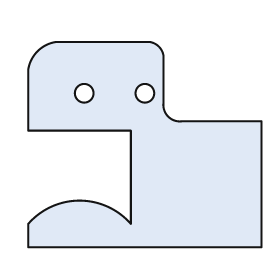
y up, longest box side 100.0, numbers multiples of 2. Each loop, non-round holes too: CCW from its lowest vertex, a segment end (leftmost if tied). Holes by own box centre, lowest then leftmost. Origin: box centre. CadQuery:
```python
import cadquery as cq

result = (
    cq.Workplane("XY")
    .moveTo(-50.0, -44.0)
    .lineTo(50.0, -44.0)
    .lineTo(50.0, 10.0)
    .lineTo(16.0, 10.0)
    .threePointArc((10.0, 12.0), (8.0, 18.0))
    .lineTo(8.0, 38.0)
    .threePointArc((6.0, 42.0), (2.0, 44.0))
    .lineTo(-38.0, 44.0)
    .threePointArc((-46.0, 40.0), (-50.0, 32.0))
    .lineTo(-50.0, 6.0)
    .lineTo(-6.0, 6.0)
    .lineTo(-6.0, -34.0)
    .threePointArc((-28.0, -24.0), (-50.0, -34.0))
    .close()
    .moveTo(-26.0, 22.0)
    .circle(4.0)
    .moveTo(0.0, 22.0)
    .circle(4.0)
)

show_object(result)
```